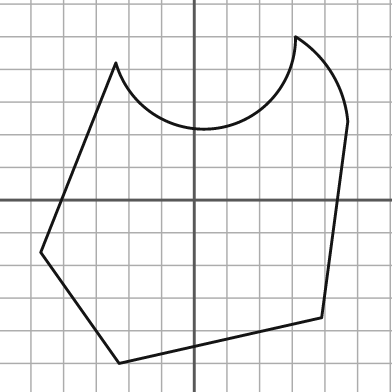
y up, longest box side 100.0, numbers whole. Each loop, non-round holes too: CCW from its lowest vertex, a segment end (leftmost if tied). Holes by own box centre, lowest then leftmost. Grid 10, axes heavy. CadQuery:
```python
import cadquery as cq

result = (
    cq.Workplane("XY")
    .moveTo(-23.0, -50.0)
    .lineTo(39.0, -36.0)
    .lineTo(47.0, 24.0)
    .threePointArc((42.0, 39.0), (31.0, 50.0))
    .threePointArc((7.0, 22.0), (-24.0, 42.0))
    .lineTo(-47.0, -16.0)
    .close()
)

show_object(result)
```